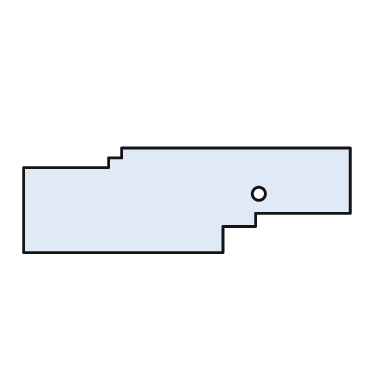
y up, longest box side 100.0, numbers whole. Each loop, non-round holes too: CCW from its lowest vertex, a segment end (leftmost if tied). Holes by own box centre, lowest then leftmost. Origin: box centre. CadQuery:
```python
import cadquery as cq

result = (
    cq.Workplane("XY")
    .moveTo(-50.0, -16.0)
    .lineTo(11.0, -16.0)
    .lineTo(11.0, -8.0)
    .lineTo(21.0, -8.0)
    .lineTo(21.0, -4.0)
    .lineTo(50.0, -4.0)
    .lineTo(50.0, 16.0)
    .lineTo(-20.0, 16.0)
    .lineTo(-20.0, 13.0)
    .lineTo(-24.0, 13.0)
    .lineTo(-24.0, 10.0)
    .lineTo(-50.0, 10.0)
    .close()
    .moveTo(22.0, 2.0)
    .circle(2.0)
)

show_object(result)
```